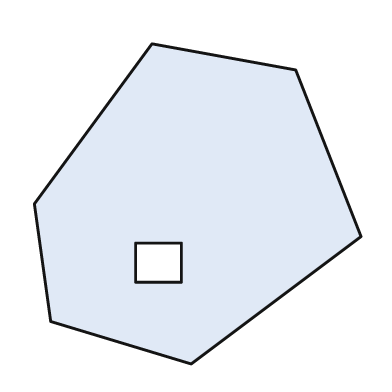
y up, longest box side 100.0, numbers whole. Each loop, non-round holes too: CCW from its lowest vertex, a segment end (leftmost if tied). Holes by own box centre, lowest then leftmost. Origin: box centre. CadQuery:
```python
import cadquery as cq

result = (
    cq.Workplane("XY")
    .moveTo(-2.0, -49.0)
    .lineTo(50.0, -10.0)
    .lineTo(30.0, 41.0)
    .lineTo(-14.0, 49.0)
    .lineTo(-50.0, 0.0)
    .lineTo(-45.0, -36.0)
    .close()
    .moveTo(-19.0, -24.0)
    .lineTo(-5.0, -24.0)
    .lineTo(-5.0, -12.0)
    .lineTo(-19.0, -12.0)
    .close()
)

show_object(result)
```